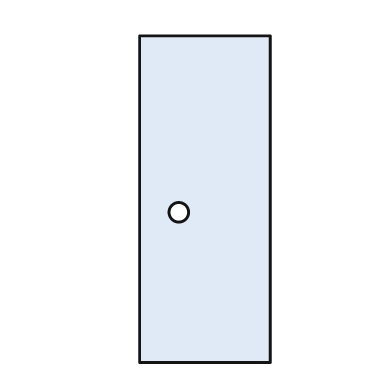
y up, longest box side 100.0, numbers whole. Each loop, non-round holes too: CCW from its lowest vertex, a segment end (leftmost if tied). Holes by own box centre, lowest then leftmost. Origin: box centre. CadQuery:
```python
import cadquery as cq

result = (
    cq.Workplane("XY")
    .moveTo(-20.0, -50.0)
    .lineTo(20.0, -50.0)
    .lineTo(20.0, 50.0)
    .lineTo(-20.0, 50.0)
    .close()
    .moveTo(-8.0, -4.0)
    .circle(3.0)
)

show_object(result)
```